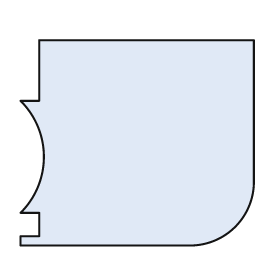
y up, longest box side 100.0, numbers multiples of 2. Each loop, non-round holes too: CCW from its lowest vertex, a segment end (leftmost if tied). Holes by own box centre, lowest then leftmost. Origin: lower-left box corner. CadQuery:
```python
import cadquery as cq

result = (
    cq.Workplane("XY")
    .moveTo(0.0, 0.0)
    .lineTo(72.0, 0.0)
    .threePointArc((92.0, 8.0), (100.0, 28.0))
    .lineTo(100.0, 88.0)
    .lineTo(8.0, 88.0)
    .lineTo(8.0, 62.0)
    .lineTo(0.0, 62.0)
    .threePointArc((10.0, 38.0), (0.0, 14.0))
    .lineTo(8.0, 14.0)
    .lineTo(8.0, 4.0)
    .lineTo(0.0, 4.0)
    .close()
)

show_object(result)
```